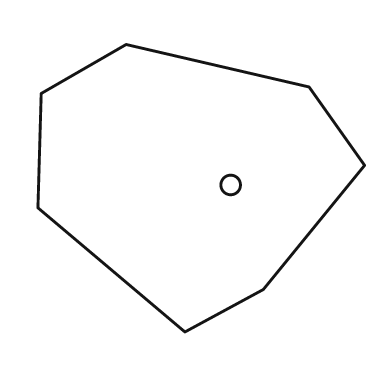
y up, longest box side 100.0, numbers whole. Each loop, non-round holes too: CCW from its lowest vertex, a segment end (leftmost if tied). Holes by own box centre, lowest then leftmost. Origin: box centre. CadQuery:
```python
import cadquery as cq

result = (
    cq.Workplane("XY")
    .moveTo(-5.0, -44.0)
    .lineTo(19.0, -31.0)
    .lineTo(50.0, 7.0)
    .lineTo(33.0, 31.0)
    .lineTo(-23.0, 44.0)
    .lineTo(-49.0, 29.0)
    .lineTo(-50.0, -6.0)
    .close()
    .moveTo(9.0, 1.0)
    .circle(3.0)
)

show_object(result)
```